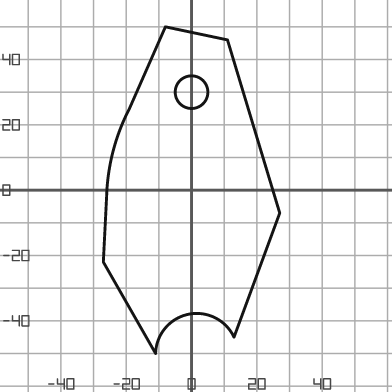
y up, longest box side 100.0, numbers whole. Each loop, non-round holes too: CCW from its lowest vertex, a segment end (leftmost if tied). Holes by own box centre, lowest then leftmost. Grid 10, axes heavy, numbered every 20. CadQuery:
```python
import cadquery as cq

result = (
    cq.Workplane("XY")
    .moveTo(-11.0, -50.0)
    .threePointArc((-1.0, -38.0), (13.0, -45.0))
    .lineTo(27.0, -7.0)
    .lineTo(11.0, 46.0)
    .lineTo(-8.0, 50.0)
    .lineTo(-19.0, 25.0)
    .threePointArc((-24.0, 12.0), (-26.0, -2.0))
    .lineTo(-27.0, -22.0)
    .close()
    .moveTo(0.0, 30.0)
    .circle(5.0)
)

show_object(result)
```